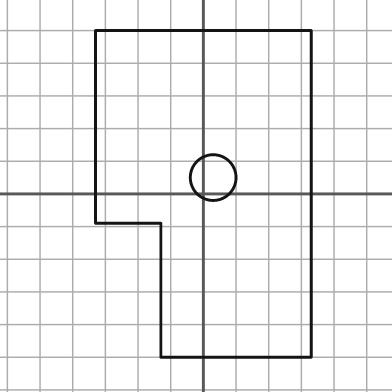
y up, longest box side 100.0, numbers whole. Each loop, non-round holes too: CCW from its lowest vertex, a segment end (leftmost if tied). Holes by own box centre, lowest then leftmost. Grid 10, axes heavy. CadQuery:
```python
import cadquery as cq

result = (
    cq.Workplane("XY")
    .moveTo(-13.0, -50.0)
    .lineTo(33.0, -50.0)
    .lineTo(33.0, 50.0)
    .lineTo(-33.0, 50.0)
    .lineTo(-33.0, -9.0)
    .lineTo(-13.0, -9.0)
    .close()
    .moveTo(3.0, 5.0)
    .circle(7.0)
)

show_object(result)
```